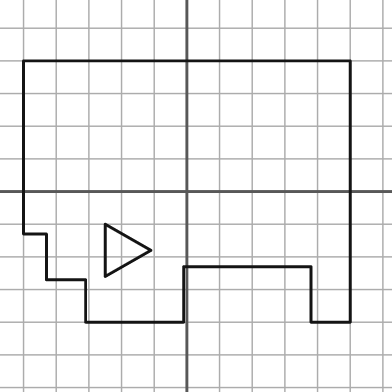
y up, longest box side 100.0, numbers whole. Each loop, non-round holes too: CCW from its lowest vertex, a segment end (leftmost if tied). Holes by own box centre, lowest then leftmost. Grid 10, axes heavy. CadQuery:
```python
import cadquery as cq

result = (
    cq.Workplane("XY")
    .moveTo(-31.0, -40.0)
    .lineTo(-1.0, -40.0)
    .lineTo(-1.0, -23.0)
    .lineTo(38.0, -23.0)
    .lineTo(38.0, -40.0)
    .lineTo(50.0, -40.0)
    .lineTo(50.0, 40.0)
    .lineTo(-50.0, 40.0)
    .lineTo(-50.0, -13.0)
    .lineTo(-43.0, -13.0)
    .lineTo(-43.0, -27.0)
    .lineTo(-31.0, -27.0)
    .close()
    .moveTo(-25.0, -26.0)
    .lineTo(-11.0, -18.0)
    .lineTo(-25.0, -10.0)
    .close()
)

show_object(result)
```